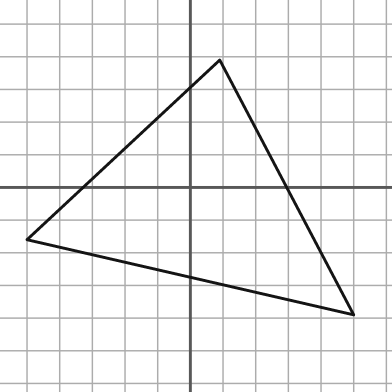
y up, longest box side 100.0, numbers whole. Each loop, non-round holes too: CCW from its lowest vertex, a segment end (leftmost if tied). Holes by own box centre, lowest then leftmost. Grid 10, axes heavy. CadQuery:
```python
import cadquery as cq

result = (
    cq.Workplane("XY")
    .moveTo(50.0, -39.0)
    .lineTo(9.0, 39.0)
    .lineTo(-50.0, -16.0)
    .close()
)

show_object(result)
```